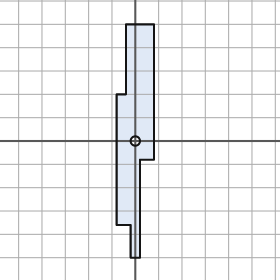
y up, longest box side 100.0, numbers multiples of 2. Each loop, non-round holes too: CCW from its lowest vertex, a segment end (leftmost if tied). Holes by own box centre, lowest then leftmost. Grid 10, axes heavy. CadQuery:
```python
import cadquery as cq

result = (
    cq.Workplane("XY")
    .moveTo(-2.0, -50.0)
    .lineTo(2.0, -50.0)
    .lineTo(2.0, -8.0)
    .lineTo(8.0, -8.0)
    .lineTo(8.0, 50.0)
    .lineTo(-4.0, 50.0)
    .lineTo(-4.0, 20.0)
    .lineTo(-8.0, 20.0)
    .lineTo(-8.0, -36.0)
    .lineTo(-2.0, -36.0)
    .close()
    .moveTo(0.0, 0.0)
    .circle(2.0)
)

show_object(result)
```